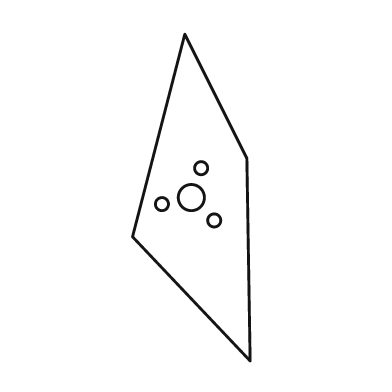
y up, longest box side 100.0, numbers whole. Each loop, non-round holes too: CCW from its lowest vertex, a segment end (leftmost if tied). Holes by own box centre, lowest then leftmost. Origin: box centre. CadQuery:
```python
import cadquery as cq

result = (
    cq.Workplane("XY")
    .moveTo(18.0, -50.0)
    .lineTo(17.0, 12.0)
    .lineTo(-2.0, 50.0)
    .lineTo(-18.0, -12.0)
    .close()
    .moveTo(7.0, -7.0)
    .circle(2.0)
    .moveTo(-9.0, -2.0)
    .circle(2.0)
    .moveTo(0.0, 0.0)
    .circle(4.0)
    .moveTo(3.0, 9.0)
    .circle(2.0)
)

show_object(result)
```